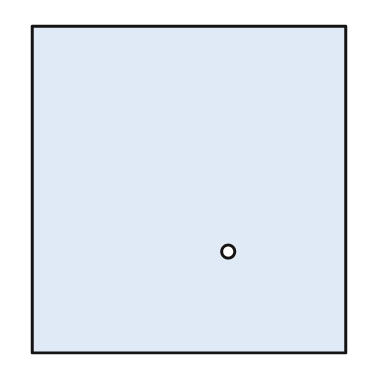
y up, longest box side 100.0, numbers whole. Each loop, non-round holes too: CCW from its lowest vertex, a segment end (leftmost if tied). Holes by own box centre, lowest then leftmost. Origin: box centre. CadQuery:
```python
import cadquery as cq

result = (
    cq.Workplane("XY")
    .moveTo(-48.0, -50.0)
    .lineTo(48.0, -50.0)
    .lineTo(48.0, 50.0)
    .lineTo(-48.0, 50.0)
    .close()
    .moveTo(12.0, -19.0)
    .circle(2.0)
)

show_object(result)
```